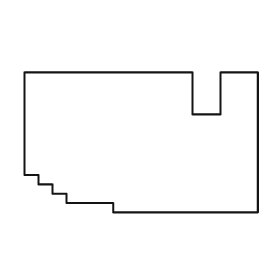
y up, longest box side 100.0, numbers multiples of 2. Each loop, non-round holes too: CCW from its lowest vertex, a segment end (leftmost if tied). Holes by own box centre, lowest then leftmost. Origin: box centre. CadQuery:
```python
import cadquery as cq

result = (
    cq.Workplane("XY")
    .moveTo(-12.0, -30.0)
    .lineTo(50.0, -30.0)
    .lineTo(50.0, 30.0)
    .lineTo(34.0, 30.0)
    .lineTo(34.0, 12.0)
    .lineTo(22.0, 12.0)
    .lineTo(22.0, 30.0)
    .lineTo(-50.0, 30.0)
    .lineTo(-50.0, -14.0)
    .lineTo(-44.0, -14.0)
    .lineTo(-44.0, -18.0)
    .lineTo(-38.0, -18.0)
    .lineTo(-38.0, -22.0)
    .lineTo(-32.0, -22.0)
    .lineTo(-32.0, -26.0)
    .lineTo(-12.0, -26.0)
    .close()
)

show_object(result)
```